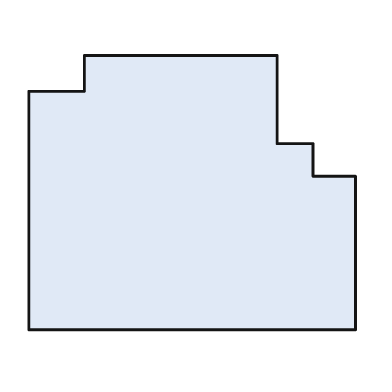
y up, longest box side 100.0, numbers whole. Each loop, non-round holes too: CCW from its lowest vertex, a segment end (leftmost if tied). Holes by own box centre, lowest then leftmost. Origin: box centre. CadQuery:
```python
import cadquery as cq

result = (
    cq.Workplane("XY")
    .moveTo(-50.0, -42.0)
    .lineTo(50.0, -42.0)
    .lineTo(50.0, 5.0)
    .lineTo(37.0, 5.0)
    .lineTo(37.0, 15.0)
    .lineTo(26.0, 15.0)
    .lineTo(26.0, 42.0)
    .lineTo(-33.0, 42.0)
    .lineTo(-33.0, 31.0)
    .lineTo(-50.0, 31.0)
    .close()
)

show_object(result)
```